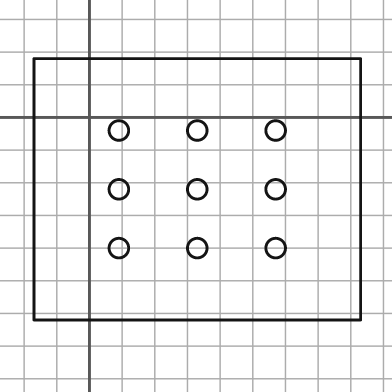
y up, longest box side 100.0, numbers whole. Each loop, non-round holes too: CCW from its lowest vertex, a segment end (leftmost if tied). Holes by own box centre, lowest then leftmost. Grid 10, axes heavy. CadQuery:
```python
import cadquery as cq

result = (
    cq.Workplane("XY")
    .moveTo(-17.0, -62.0)
    .lineTo(83.0, -62.0)
    .lineTo(83.0, 18.0)
    .lineTo(-17.0, 18.0)
    .close()
    .moveTo(9.0, -40.0)
    .circle(3.0)
    .moveTo(33.0, -40.0)
    .circle(3.0)
    .moveTo(57.0, -40.0)
    .circle(3.0)
    .moveTo(9.0, -22.0)
    .circle(3.0)
    .moveTo(33.0, -22.0)
    .circle(3.0)
    .moveTo(57.0, -22.0)
    .circle(3.0)
    .moveTo(9.0, -4.0)
    .circle(3.0)
    .moveTo(33.0, -4.0)
    .circle(3.0)
    .moveTo(57.0, -4.0)
    .circle(3.0)
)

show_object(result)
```